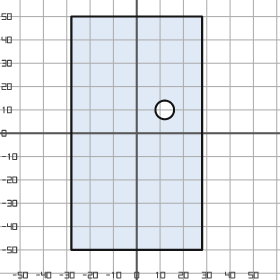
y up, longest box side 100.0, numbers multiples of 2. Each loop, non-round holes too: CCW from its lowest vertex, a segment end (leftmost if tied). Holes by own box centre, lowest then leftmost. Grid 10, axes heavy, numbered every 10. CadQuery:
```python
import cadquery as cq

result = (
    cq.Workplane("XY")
    .moveTo(-28.0, -50.0)
    .lineTo(28.0, -50.0)
    .lineTo(28.0, 50.0)
    .lineTo(-28.0, 50.0)
    .close()
    .moveTo(12.0, 10.0)
    .circle(4.0)
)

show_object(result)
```